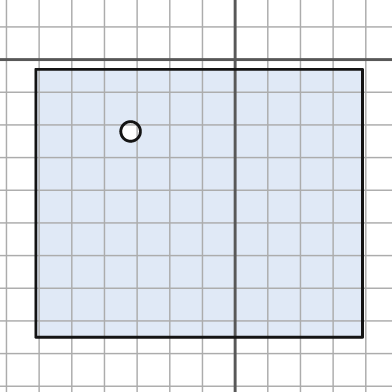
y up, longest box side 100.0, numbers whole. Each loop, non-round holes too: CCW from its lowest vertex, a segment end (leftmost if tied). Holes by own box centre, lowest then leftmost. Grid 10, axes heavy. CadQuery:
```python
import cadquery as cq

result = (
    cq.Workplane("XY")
    .moveTo(-61.0, -85.0)
    .lineTo(39.0, -85.0)
    .lineTo(39.0, -3.0)
    .lineTo(-61.0, -3.0)
    .close()
    .moveTo(-32.0, -22.0)
    .circle(3.0)
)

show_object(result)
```